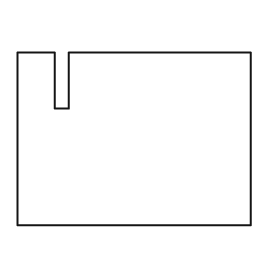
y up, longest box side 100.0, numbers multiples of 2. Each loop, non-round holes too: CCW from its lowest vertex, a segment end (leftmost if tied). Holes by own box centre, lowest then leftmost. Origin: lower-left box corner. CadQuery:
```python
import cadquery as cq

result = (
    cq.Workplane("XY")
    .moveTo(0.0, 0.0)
    .lineTo(100.0, 0.0)
    .lineTo(100.0, 74.0)
    .lineTo(22.0, 74.0)
    .lineTo(22.0, 50.0)
    .lineTo(16.0, 50.0)
    .lineTo(16.0, 74.0)
    .lineTo(0.0, 74.0)
    .close()
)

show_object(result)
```